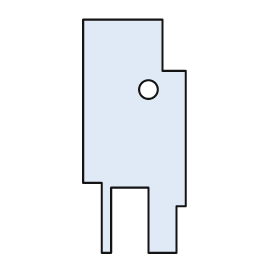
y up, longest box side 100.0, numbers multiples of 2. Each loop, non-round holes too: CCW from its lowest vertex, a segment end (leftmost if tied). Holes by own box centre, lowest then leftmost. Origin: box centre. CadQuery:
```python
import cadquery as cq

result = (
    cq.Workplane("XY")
    .moveTo(-14.0, -50.0)
    .lineTo(-10.0, -50.0)
    .lineTo(-10.0, -22.0)
    .lineTo(6.0, -22.0)
    .lineTo(6.0, -50.0)
    .lineTo(18.0, -50.0)
    .lineTo(18.0, -30.0)
    .lineTo(22.0, -30.0)
    .lineTo(22.0, 28.0)
    .lineTo(12.0, 28.0)
    .lineTo(12.0, 50.0)
    .lineTo(-22.0, 50.0)
    .lineTo(-22.0, -20.0)
    .lineTo(-14.0, -20.0)
    .close()
    .moveTo(6.0, 20.0)
    .circle(4.0)
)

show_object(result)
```